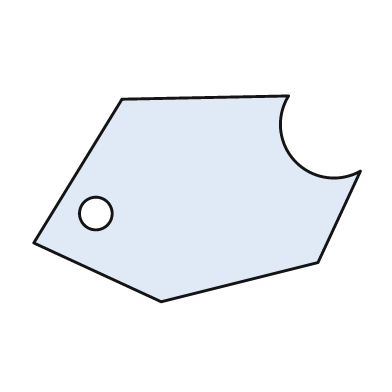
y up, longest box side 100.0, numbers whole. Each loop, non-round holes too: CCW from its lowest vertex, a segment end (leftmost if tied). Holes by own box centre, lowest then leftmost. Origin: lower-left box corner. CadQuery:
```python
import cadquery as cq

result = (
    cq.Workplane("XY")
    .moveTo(39.0, 0.0)
    .lineTo(87.0, 12.0)
    .lineTo(100.0, 40.0)
    .threePointArc((80.0, 43.0), (78.0, 63.0))
    .lineTo(27.0, 62.0)
    .lineTo(0.0, 18.0)
    .close()
    .moveTo(19.0, 27.0)
    .circle(5.0)
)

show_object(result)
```